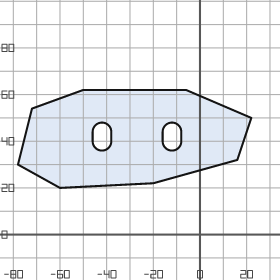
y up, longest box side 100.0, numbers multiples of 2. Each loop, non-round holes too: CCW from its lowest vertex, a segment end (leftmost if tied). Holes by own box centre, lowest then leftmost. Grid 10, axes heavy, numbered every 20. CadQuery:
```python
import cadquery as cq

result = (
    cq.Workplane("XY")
    .moveTo(-60.0, 20.0)
    .lineTo(-20.0, 22.0)
    .lineTo(16.0, 32.0)
    .lineTo(22.0, 50.0)
    .lineTo(-6.0, 62.0)
    .lineTo(-50.0, 62.0)
    .lineTo(-72.0, 54.0)
    .lineTo(-78.0, 30.0)
    .close()
    .moveTo(-46.0, 40.0)
    .threePointArc((-42.0, 36.0), (-38.0, 40.0))
    .lineTo(-38.0, 44.0)
    .threePointArc((-42.0, 48.0), (-46.0, 44.0))
    .close()
    .moveTo(-16.0, 40.0)
    .threePointArc((-12.0, 36.0), (-8.0, 40.0))
    .lineTo(-8.0, 44.0)
    .threePointArc((-12.0, 48.0), (-16.0, 44.0))
    .close()
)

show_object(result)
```